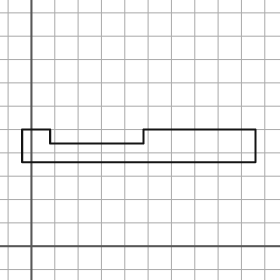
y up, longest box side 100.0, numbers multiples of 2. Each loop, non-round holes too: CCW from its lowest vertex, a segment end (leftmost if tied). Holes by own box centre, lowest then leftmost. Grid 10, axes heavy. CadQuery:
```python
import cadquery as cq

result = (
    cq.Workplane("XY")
    .moveTo(-4.0, 36.0)
    .lineTo(96.0, 36.0)
    .lineTo(96.0, 50.0)
    .lineTo(48.0, 50.0)
    .lineTo(48.0, 44.0)
    .lineTo(8.0, 44.0)
    .lineTo(8.0, 50.0)
    .lineTo(-4.0, 50.0)
    .close()
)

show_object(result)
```